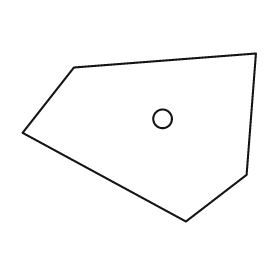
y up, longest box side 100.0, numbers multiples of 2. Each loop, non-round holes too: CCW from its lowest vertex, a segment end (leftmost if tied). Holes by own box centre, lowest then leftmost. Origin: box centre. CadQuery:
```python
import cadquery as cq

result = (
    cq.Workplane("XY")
    .moveTo(20.0, -36.0)
    .lineTo(46.0, -16.0)
    .lineTo(50.0, 36.0)
    .lineTo(-28.0, 30.0)
    .lineTo(-50.0, 2.0)
    .close()
    .moveTo(10.0, 8.0)
    .circle(4.0)
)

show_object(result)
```